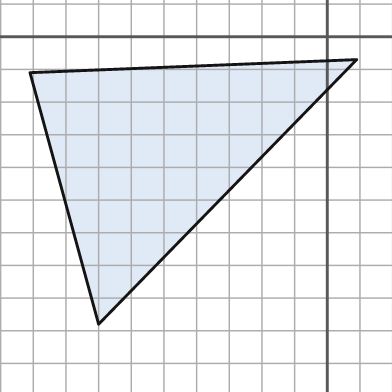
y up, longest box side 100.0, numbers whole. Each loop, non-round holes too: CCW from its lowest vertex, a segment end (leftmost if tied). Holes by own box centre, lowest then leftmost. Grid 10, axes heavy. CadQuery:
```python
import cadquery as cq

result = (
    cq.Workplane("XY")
    .moveTo(-70.0, -88.0)
    .lineTo(9.0, -7.0)
    .lineTo(-91.0, -11.0)
    .close()
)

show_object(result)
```